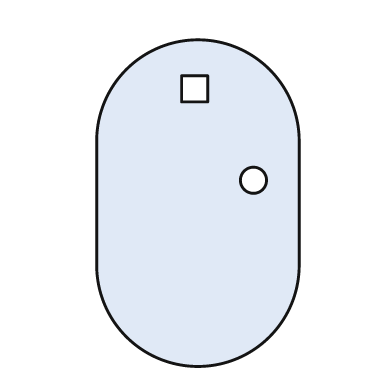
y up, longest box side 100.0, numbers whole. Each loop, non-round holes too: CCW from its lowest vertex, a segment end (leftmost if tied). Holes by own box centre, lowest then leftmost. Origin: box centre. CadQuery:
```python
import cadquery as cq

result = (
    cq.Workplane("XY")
    .moveTo(-31.0, -19.0)
    .threePointArc((0.0, -50.0), (31.0, -19.0))
    .lineTo(31.0, 19.0)
    .threePointArc((0.0, 50.0), (-31.0, 19.0))
    .close()
    .moveTo(17.0, 7.0)
    .circle(4.0)
    .moveTo(-5.0, 31.0)
    .lineTo(3.0, 31.0)
    .lineTo(3.0, 39.0)
    .lineTo(-5.0, 39.0)
    .close()
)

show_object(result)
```